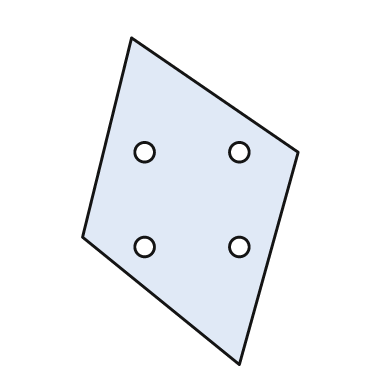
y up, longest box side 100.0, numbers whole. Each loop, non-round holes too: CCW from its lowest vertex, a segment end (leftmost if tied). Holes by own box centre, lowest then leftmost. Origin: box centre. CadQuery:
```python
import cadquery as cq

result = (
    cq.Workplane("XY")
    .moveTo(15.0, -50.0)
    .lineTo(33.0, 15.0)
    .lineTo(-18.0, 50.0)
    .lineTo(-33.0, -11.0)
    .close()
    .moveTo(-14.0, -14.0)
    .circle(3.0)
    .moveTo(15.0, -14.0)
    .circle(3.0)
    .moveTo(-14.0, 15.0)
    .circle(3.0)
    .moveTo(15.0, 15.0)
    .circle(3.0)
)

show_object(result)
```